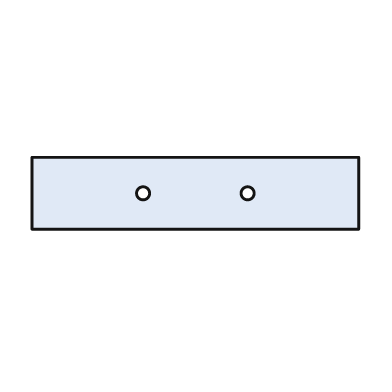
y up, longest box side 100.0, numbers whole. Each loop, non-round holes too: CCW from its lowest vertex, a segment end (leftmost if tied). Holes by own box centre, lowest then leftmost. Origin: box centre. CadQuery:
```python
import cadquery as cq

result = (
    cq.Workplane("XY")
    .moveTo(-50.0, -11.0)
    .lineTo(50.0, -11.0)
    .lineTo(50.0, 11.0)
    .lineTo(-50.0, 11.0)
    .close()
    .moveTo(-16.0, 0.0)
    .circle(2.0)
    .moveTo(16.0, 0.0)
    .circle(2.0)
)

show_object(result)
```